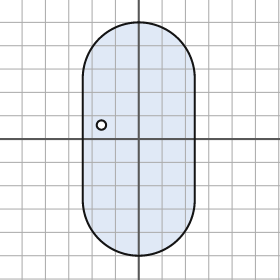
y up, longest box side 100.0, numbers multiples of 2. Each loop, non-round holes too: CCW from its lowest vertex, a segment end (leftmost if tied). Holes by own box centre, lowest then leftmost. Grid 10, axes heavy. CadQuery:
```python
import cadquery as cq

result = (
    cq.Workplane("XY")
    .moveTo(-24.0, -26.0)
    .threePointArc((0.0, -50.0), (24.0, -26.0))
    .lineTo(24.0, 26.0)
    .threePointArc((0.0, 50.0), (-24.0, 26.0))
    .close()
    .moveTo(-16.0, 6.0)
    .circle(2.0)
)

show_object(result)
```